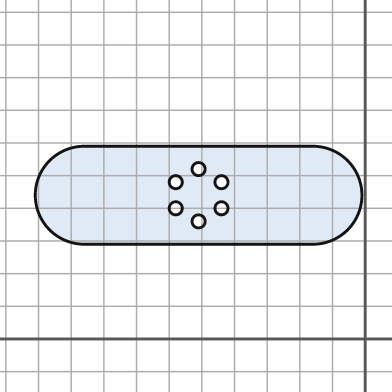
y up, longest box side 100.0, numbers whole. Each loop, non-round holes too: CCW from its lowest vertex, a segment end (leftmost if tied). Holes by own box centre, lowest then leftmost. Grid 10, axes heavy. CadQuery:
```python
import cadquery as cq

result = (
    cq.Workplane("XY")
    .moveTo(-86.0, 29.0)
    .lineTo(-16.0, 29.0)
    .threePointArc((-1.0, 44.0), (-16.0, 59.0))
    .lineTo(-86.0, 59.0)
    .threePointArc((-101.0, 44.0), (-86.0, 29.0))
    .close()
    .moveTo(-51.0, 36.0)
    .circle(2.0)
    .moveTo(-58.0, 40.0)
    .circle(2.0)
    .moveTo(-44.0, 40.0)
    .circle(2.0)
    .moveTo(-58.0, 48.0)
    .circle(2.0)
    .moveTo(-44.0, 48.0)
    .circle(2.0)
    .moveTo(-51.0, 52.0)
    .circle(2.0)
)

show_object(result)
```